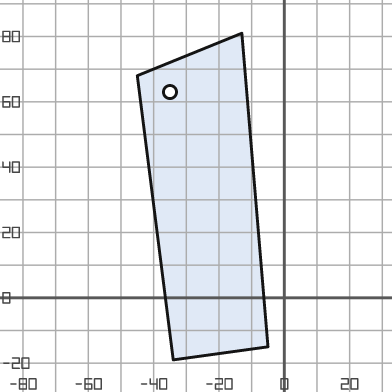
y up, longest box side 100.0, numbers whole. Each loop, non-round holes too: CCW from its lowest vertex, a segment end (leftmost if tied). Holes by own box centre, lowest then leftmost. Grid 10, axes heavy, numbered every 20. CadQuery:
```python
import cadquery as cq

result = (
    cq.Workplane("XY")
    .moveTo(-34.0, -19.0)
    .lineTo(-5.0, -15.0)
    .lineTo(-13.0, 81.0)
    .lineTo(-45.0, 68.0)
    .close()
    .moveTo(-35.0, 63.0)
    .circle(2.0)
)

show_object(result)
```